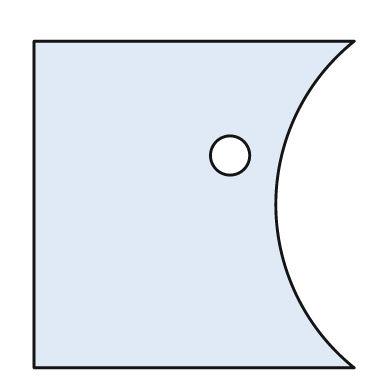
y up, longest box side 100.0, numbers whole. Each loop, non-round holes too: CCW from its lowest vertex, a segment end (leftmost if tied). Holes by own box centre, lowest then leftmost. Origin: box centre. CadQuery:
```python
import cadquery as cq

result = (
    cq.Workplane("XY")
    .moveTo(-49.0, -50.0)
    .lineTo(49.0, -50.0)
    .threePointArc((25.0, 0.0), (49.0, 50.0))
    .lineTo(-49.0, 50.0)
    .close()
    .moveTo(11.0, 15.0)
    .circle(6.0)
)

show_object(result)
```